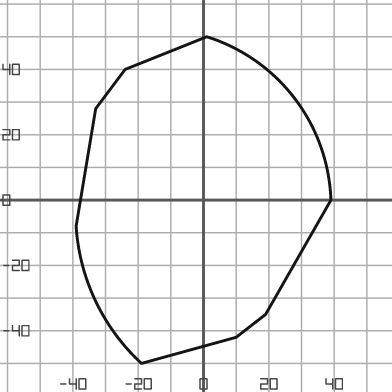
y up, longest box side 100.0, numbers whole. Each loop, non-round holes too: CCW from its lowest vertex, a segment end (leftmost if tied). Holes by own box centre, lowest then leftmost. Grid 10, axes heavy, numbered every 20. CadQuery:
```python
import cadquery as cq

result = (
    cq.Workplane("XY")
    .moveTo(-19.0, -50.0)
    .lineTo(10.0, -42.0)
    .lineTo(19.0, -35.0)
    .lineTo(39.0, 0.0)
    .threePointArc((28.0, 31.0), (1.0, 50.0))
    .lineTo(-24.0, 40.0)
    .lineTo(-33.0, 28.0)
    .lineTo(-39.0, -8.0)
    .threePointArc((-33.0, -31.0), (-19.0, -50.0))
    .close()
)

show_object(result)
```